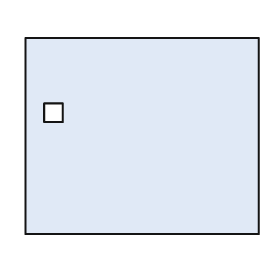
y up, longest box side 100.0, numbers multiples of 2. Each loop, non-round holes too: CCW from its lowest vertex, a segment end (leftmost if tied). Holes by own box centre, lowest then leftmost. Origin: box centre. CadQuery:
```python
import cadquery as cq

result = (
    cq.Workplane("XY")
    .moveTo(-50.0, -42.0)
    .lineTo(50.0, -42.0)
    .lineTo(50.0, 42.0)
    .lineTo(-50.0, 42.0)
    .close()
    .moveTo(-42.0, 6.0)
    .lineTo(-34.0, 6.0)
    .lineTo(-34.0, 14.0)
    .lineTo(-42.0, 14.0)
    .close()
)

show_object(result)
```